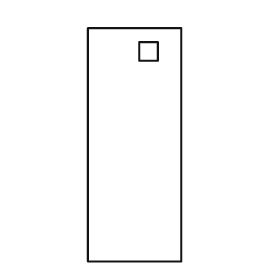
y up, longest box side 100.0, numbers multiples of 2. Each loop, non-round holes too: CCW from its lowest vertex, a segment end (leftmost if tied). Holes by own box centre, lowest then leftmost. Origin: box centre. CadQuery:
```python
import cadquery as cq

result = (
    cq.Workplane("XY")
    .moveTo(-20.0, -50.0)
    .lineTo(20.0, -50.0)
    .lineTo(20.0, 50.0)
    .lineTo(-20.0, 50.0)
    .close()
    .moveTo(2.0, 36.0)
    .lineTo(10.0, 36.0)
    .lineTo(10.0, 44.0)
    .lineTo(2.0, 44.0)
    .close()
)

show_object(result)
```